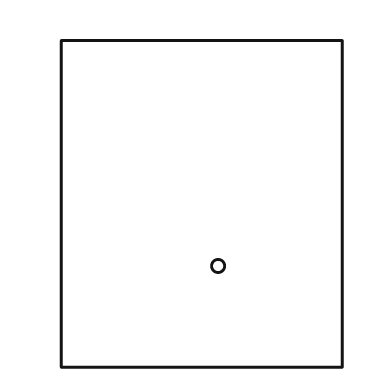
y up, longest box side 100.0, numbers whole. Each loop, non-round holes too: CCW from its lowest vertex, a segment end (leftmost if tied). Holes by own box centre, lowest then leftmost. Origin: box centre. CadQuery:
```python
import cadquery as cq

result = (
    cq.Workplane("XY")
    .moveTo(-43.0, -50.0)
    .lineTo(43.0, -50.0)
    .lineTo(43.0, 50.0)
    .lineTo(-43.0, 50.0)
    .close()
    .moveTo(5.0, -19.0)
    .circle(2.0)
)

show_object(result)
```